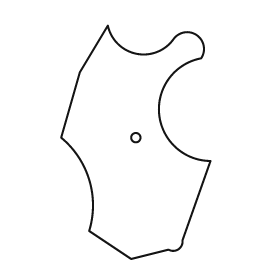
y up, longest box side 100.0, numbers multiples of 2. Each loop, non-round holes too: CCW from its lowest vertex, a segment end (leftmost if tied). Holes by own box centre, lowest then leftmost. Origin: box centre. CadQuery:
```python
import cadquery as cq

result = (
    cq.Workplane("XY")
    .moveTo(-2.0, -50.0)
    .lineTo(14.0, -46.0)
    .threePointArc((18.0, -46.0), (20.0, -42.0))
    .lineTo(32.0, -8.0)
    .threePointArc((10.0, 12.0), (28.0, 36.0))
    .threePointArc((26.0, 46.0), (16.0, 44.0))
    .threePointArc((0.0, 38.0), (-12.0, 50.0))
    .lineTo(-24.0, 30.0)
    .lineTo(-32.0, 2.0)
    .threePointArc((-20.0, -16.0), (-20.0, -38.0))
    .close()
    .moveTo(0.0, 2.0)
    .circle(2.0)
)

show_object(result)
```